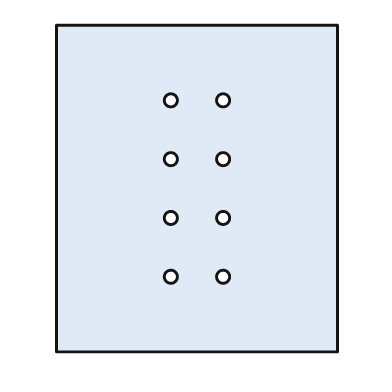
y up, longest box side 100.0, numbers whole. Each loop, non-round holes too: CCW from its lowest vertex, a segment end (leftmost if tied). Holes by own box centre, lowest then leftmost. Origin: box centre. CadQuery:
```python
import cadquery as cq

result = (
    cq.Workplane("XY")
    .moveTo(-43.0, -50.0)
    .lineTo(43.0, -50.0)
    .lineTo(43.0, 50.0)
    .lineTo(-43.0, 50.0)
    .close()
    .moveTo(-8.0, -27.0)
    .circle(2.0)
    .moveTo(8.0, -27.0)
    .circle(2.0)
    .moveTo(-8.0, -9.0)
    .circle(2.0)
    .moveTo(8.0, -9.0)
    .circle(2.0)
    .moveTo(-8.0, 9.0)
    .circle(2.0)
    .moveTo(8.0, 9.0)
    .circle(2.0)
    .moveTo(-8.0, 27.0)
    .circle(2.0)
    .moveTo(8.0, 27.0)
    .circle(2.0)
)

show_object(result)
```